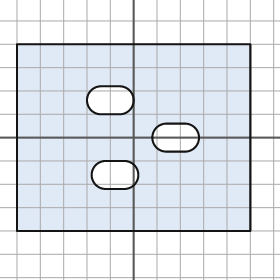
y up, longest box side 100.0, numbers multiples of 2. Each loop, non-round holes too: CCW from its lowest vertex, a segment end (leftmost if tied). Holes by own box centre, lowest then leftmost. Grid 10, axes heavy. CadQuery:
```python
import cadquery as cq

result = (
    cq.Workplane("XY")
    .moveTo(-50.0, -40.0)
    .lineTo(50.0, -40.0)
    .lineTo(50.0, 40.0)
    .lineTo(-50.0, 40.0)
    .close()
    .moveTo(-12.0, -22.0)
    .lineTo(-4.0, -22.0)
    .threePointArc((2.0, -16.0), (-4.0, -10.0))
    .lineTo(-12.0, -10.0)
    .threePointArc((-18.0, -16.0), (-12.0, -22.0))
    .close()
    .moveTo(14.0, -6.0)
    .lineTo(22.0, -6.0)
    .threePointArc((28.0, 0.0), (22.0, 6.0))
    .lineTo(14.0, 6.0)
    .threePointArc((8.0, 0.0), (14.0, -6.0))
    .close()
    .moveTo(-14.0, 10.0)
    .lineTo(-6.0, 10.0)
    .threePointArc((0.0, 16.0), (-6.0, 22.0))
    .lineTo(-14.0, 22.0)
    .threePointArc((-20.0, 16.0), (-14.0, 10.0))
    .close()
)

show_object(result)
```